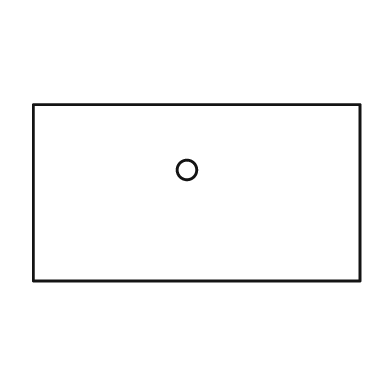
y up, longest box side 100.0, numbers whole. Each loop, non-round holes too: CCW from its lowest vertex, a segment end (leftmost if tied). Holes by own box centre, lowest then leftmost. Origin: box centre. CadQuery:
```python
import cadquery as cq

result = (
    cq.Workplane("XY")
    .moveTo(-50.0, -27.0)
    .lineTo(50.0, -27.0)
    .lineTo(50.0, 27.0)
    .lineTo(-50.0, 27.0)
    .close()
    .moveTo(-3.0, 7.0)
    .circle(3.0)
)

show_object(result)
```